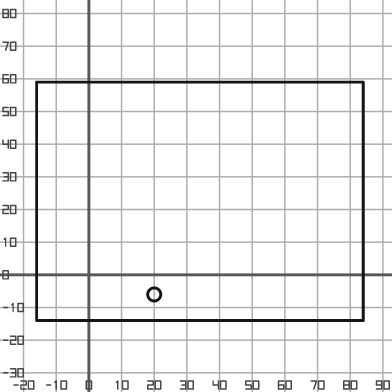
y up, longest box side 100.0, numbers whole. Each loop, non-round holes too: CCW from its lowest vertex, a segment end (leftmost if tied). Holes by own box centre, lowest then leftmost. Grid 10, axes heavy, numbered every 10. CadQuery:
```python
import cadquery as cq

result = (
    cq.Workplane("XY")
    .moveTo(-16.0, -14.0)
    .lineTo(84.0, -14.0)
    .lineTo(84.0, 59.0)
    .lineTo(-16.0, 59.0)
    .close()
    .moveTo(20.0, -6.0)
    .circle(2.0)
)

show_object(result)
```